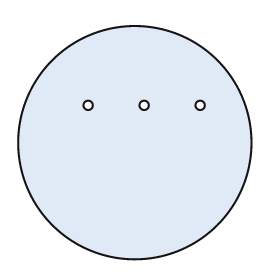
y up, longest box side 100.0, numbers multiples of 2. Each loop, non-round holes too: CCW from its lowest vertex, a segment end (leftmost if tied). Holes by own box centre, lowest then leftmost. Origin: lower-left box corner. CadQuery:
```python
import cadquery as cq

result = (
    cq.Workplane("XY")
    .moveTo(50.0, 50.0)
    .circle(50.0)
    .moveTo(30.0, 66.0)
    .circle(2.0)
    .moveTo(54.0, 66.0)
    .circle(2.0)
    .moveTo(78.0, 66.0)
    .circle(2.0)
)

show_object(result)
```